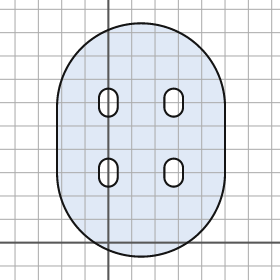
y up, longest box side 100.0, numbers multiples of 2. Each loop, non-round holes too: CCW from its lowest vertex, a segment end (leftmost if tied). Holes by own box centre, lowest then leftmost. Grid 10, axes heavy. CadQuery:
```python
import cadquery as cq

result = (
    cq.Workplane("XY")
    .moveTo(-22.0, 30.0)
    .threePointArc((14.0, -6.0), (50.0, 30.0))
    .lineTo(50.0, 58.0)
    .threePointArc((14.0, 94.0), (-22.0, 58.0))
    .close()
    .moveTo(-4.0, 28.0)
    .threePointArc((0.0, 24.0), (4.0, 28.0))
    .lineTo(4.0, 32.0)
    .threePointArc((0.0, 36.0), (-4.0, 32.0))
    .close()
    .moveTo(24.0, 28.0)
    .threePointArc((28.0, 24.0), (32.0, 28.0))
    .lineTo(32.0, 32.0)
    .threePointArc((28.0, 36.0), (24.0, 32.0))
    .close()
    .moveTo(-4.0, 58.0)
    .threePointArc((0.0, 54.0), (4.0, 58.0))
    .lineTo(4.0, 62.0)
    .threePointArc((0.0, 66.0), (-4.0, 62.0))
    .close()
    .moveTo(24.0, 58.0)
    .threePointArc((28.0, 54.0), (32.0, 58.0))
    .lineTo(32.0, 62.0)
    .threePointArc((28.0, 66.0), (24.0, 62.0))
    .close()
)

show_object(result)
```